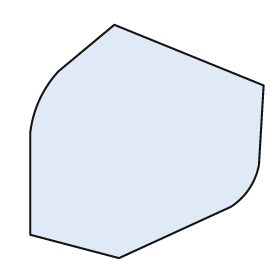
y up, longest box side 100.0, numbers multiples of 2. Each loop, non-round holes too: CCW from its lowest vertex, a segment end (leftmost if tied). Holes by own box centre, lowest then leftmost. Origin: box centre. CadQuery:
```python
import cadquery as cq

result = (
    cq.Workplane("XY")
    .moveTo(-12.0, -50.0)
    .lineTo(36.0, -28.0)
    .threePointArc((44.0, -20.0), (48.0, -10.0))
    .lineTo(50.0, 24.0)
    .lineTo(-14.0, 50.0)
    .lineTo(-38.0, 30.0)
    .threePointArc((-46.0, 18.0), (-50.0, 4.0))
    .lineTo(-50.0, -40.0)
    .close()
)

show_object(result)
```